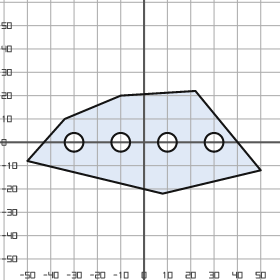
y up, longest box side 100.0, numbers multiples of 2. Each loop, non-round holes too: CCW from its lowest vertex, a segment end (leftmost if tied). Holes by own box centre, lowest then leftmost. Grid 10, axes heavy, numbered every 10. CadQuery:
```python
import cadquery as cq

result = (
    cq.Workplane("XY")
    .moveTo(8.0, -22.0)
    .lineTo(50.0, -12.0)
    .lineTo(22.0, 22.0)
    .lineTo(-10.0, 20.0)
    .lineTo(-34.0, 10.0)
    .lineTo(-50.0, -8.0)
    .close()
    .moveTo(-30.0, 0.0)
    .circle(4.0)
    .moveTo(-10.0, 0.0)
    .circle(4.0)
    .moveTo(10.0, 0.0)
    .circle(4.0)
    .moveTo(30.0, 0.0)
    .circle(4.0)
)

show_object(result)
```